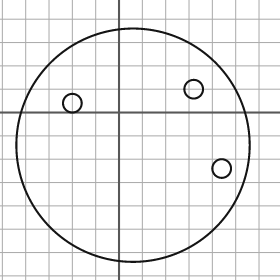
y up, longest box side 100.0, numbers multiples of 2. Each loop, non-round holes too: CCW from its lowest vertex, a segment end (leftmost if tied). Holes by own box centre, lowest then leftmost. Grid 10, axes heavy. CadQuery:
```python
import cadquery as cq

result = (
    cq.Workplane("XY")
    .moveTo(6.0, -14.0)
    .circle(50.0)
    .moveTo(44.0, -24.0)
    .circle(4.0)
    .moveTo(-20.0, 4.0)
    .circle(4.0)
    .moveTo(32.0, 10.0)
    .circle(4.0)
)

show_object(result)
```